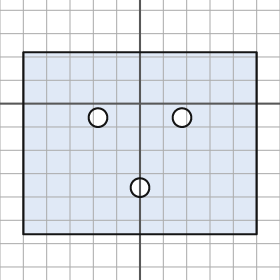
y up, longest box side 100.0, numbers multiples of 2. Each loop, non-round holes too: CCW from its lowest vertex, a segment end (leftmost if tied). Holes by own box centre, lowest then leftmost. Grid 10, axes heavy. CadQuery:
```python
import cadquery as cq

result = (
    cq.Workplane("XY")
    .moveTo(-50.0, -56.0)
    .lineTo(50.0, -56.0)
    .lineTo(50.0, 22.0)
    .lineTo(-50.0, 22.0)
    .close()
    .moveTo(0.0, -36.0)
    .circle(4.0)
    .moveTo(-18.0, -6.0)
    .circle(4.0)
    .moveTo(18.0, -6.0)
    .circle(4.0)
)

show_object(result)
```